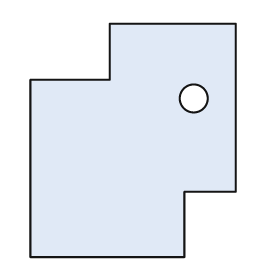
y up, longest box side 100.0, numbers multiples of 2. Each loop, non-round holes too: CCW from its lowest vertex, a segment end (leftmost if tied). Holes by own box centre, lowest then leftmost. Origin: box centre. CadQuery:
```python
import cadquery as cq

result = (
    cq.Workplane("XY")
    .moveTo(-44.0, -50.0)
    .lineTo(22.0, -50.0)
    .lineTo(22.0, -22.0)
    .lineTo(44.0, -22.0)
    .lineTo(44.0, 50.0)
    .lineTo(-10.0, 50.0)
    .lineTo(-10.0, 26.0)
    .lineTo(-44.0, 26.0)
    .close()
    .moveTo(26.0, 18.0)
    .circle(6.0)
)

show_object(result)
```